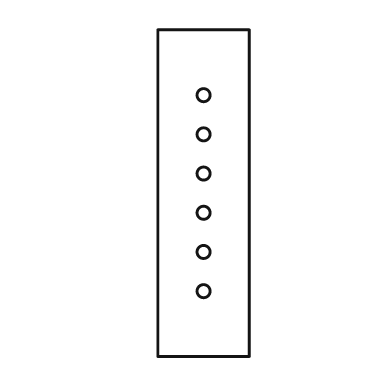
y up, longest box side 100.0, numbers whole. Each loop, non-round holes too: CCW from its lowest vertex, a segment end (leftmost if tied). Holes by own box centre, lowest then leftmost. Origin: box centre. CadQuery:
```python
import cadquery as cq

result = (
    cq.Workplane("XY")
    .moveTo(-14.0, -50.0)
    .lineTo(14.0, -50.0)
    .lineTo(14.0, 50.0)
    .lineTo(-14.0, 50.0)
    .close()
    .moveTo(0.0, -30.0)
    .circle(2.0)
    .moveTo(0.0, -18.0)
    .circle(2.0)
    .moveTo(0.0, -6.0)
    .circle(2.0)
    .moveTo(0.0, 6.0)
    .circle(2.0)
    .moveTo(0.0, 18.0)
    .circle(2.0)
    .moveTo(0.0, 30.0)
    .circle(2.0)
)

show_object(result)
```